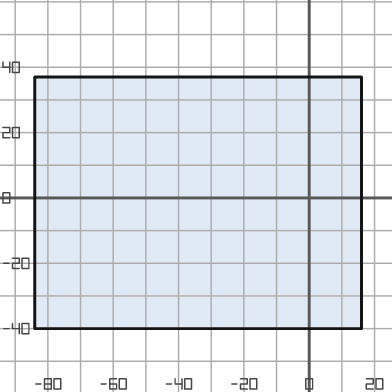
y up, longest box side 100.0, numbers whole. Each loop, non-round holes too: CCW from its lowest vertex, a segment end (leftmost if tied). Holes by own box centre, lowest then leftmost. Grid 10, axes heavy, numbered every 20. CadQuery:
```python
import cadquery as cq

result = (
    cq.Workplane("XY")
    .moveTo(-84.0, -40.0)
    .lineTo(16.0, -40.0)
    .lineTo(16.0, 37.0)
    .lineTo(-84.0, 37.0)
    .close()
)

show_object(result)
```